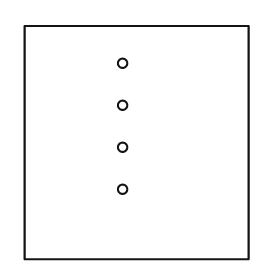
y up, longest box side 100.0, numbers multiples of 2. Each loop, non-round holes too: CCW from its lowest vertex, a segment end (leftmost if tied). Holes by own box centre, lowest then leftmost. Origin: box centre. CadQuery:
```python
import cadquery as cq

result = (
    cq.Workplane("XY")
    .moveTo(-48.0, -50.0)
    .lineTo(48.0, -50.0)
    .lineTo(48.0, 50.0)
    .lineTo(-48.0, 50.0)
    .close()
    .moveTo(-6.0, -20.0)
    .circle(2.0)
    .moveTo(-6.0, -2.0)
    .circle(2.0)
    .moveTo(-6.0, 16.0)
    .circle(2.0)
    .moveTo(-6.0, 34.0)
    .circle(2.0)
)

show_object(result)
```